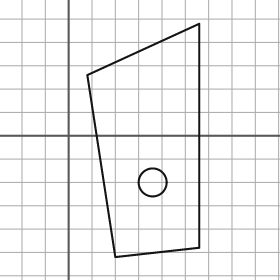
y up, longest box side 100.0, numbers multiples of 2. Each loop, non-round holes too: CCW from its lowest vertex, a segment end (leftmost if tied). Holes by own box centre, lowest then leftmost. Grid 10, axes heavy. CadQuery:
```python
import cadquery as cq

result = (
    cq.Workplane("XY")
    .moveTo(20.0, -52.0)
    .lineTo(56.0, -48.0)
    .lineTo(56.0, 48.0)
    .lineTo(8.0, 26.0)
    .close()
    .moveTo(36.0, -20.0)
    .circle(6.0)
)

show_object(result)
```